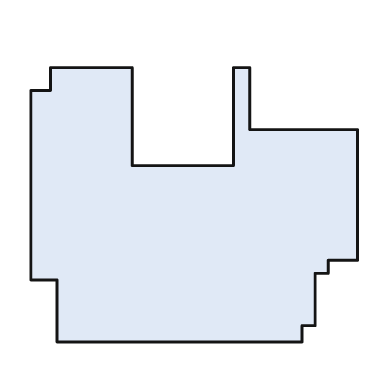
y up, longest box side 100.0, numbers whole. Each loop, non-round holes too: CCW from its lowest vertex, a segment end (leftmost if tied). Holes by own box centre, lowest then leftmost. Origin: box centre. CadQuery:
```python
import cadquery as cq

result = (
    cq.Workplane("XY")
    .moveTo(-42.0, -42.0)
    .lineTo(33.0, -42.0)
    .lineTo(33.0, -37.0)
    .lineTo(37.0, -37.0)
    .lineTo(37.0, -21.0)
    .lineTo(41.0, -21.0)
    .lineTo(41.0, -17.0)
    .lineTo(50.0, -17.0)
    .lineTo(50.0, 23.0)
    .lineTo(17.0, 23.0)
    .lineTo(17.0, 42.0)
    .lineTo(12.0, 42.0)
    .lineTo(12.0, 12.0)
    .lineTo(-19.0, 12.0)
    .lineTo(-19.0, 42.0)
    .lineTo(-44.0, 42.0)
    .lineTo(-44.0, 35.0)
    .lineTo(-50.0, 35.0)
    .lineTo(-50.0, -23.0)
    .lineTo(-42.0, -23.0)
    .close()
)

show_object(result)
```